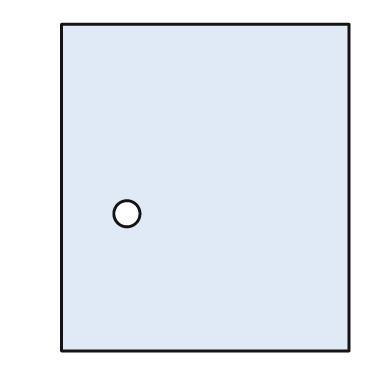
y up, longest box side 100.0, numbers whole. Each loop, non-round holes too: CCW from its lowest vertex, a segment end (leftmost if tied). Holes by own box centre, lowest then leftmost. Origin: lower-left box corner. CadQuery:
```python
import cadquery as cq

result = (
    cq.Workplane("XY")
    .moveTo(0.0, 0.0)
    .lineTo(88.0, 0.0)
    .lineTo(88.0, 100.0)
    .lineTo(0.0, 100.0)
    .close()
    .moveTo(20.0, 42.0)
    .circle(4.0)
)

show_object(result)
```